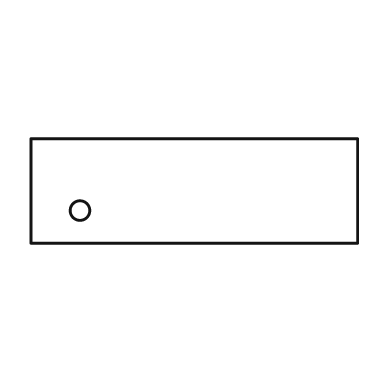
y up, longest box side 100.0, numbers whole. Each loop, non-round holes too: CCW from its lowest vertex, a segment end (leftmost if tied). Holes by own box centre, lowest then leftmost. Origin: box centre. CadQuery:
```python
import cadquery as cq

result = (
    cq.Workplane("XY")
    .moveTo(-50.0, -16.0)
    .lineTo(50.0, -16.0)
    .lineTo(50.0, 16.0)
    .lineTo(-50.0, 16.0)
    .close()
    .moveTo(-35.0, -6.0)
    .circle(3.0)
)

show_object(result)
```